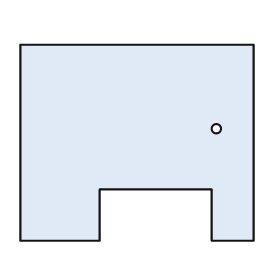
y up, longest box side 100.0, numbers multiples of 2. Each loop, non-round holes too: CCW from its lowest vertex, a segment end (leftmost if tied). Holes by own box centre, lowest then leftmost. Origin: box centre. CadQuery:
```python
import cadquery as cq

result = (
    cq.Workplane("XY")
    .moveTo(-50.0, -42.0)
    .lineTo(-16.0, -42.0)
    .lineTo(-16.0, -20.0)
    .lineTo(32.0, -20.0)
    .lineTo(32.0, -42.0)
    .lineTo(50.0, -42.0)
    .lineTo(50.0, 42.0)
    .lineTo(-50.0, 42.0)
    .close()
    .moveTo(34.0, 6.0)
    .circle(2.0)
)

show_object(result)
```